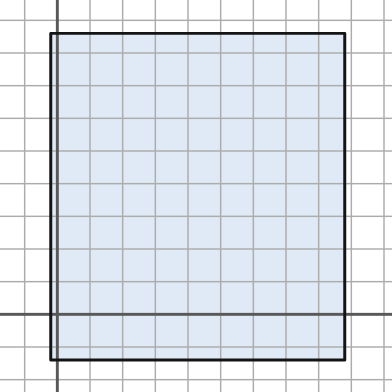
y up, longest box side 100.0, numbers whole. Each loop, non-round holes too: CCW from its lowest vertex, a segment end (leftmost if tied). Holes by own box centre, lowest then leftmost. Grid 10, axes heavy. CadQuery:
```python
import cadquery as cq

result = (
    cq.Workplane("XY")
    .moveTo(-2.0, -14.0)
    .lineTo(88.0, -14.0)
    .lineTo(88.0, 86.0)
    .lineTo(-2.0, 86.0)
    .close()
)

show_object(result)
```